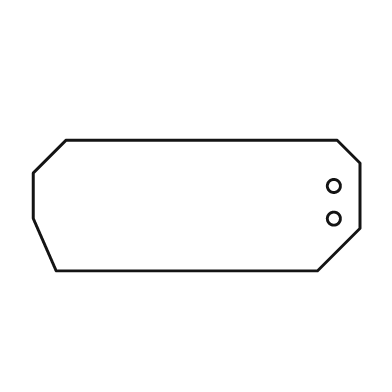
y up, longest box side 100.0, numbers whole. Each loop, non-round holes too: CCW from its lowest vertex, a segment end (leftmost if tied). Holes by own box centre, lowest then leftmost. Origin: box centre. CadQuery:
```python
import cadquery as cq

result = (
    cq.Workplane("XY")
    .moveTo(-43.0, -20.0)
    .lineTo(37.0, -20.0)
    .lineTo(50.0, -7.0)
    .lineTo(50.0, 13.0)
    .lineTo(43.0, 20.0)
    .lineTo(-40.0, 20.0)
    .lineTo(-50.0, 10.0)
    .lineTo(-50.0, -4.0)
    .close()
    .moveTo(42.0, -4.0)
    .circle(2.0)
    .moveTo(42.0, 6.0)
    .circle(2.0)
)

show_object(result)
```